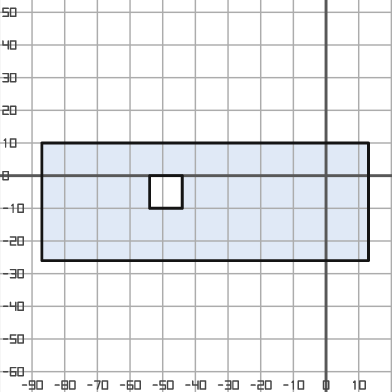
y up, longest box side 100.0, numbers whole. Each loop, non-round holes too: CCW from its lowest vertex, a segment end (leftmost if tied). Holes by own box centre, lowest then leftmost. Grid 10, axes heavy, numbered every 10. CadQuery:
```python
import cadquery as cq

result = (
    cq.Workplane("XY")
    .moveTo(-87.0, -26.0)
    .lineTo(13.0, -26.0)
    .lineTo(13.0, 10.0)
    .lineTo(-87.0, 10.0)
    .close()
    .moveTo(-54.0, -10.0)
    .lineTo(-44.0, -10.0)
    .lineTo(-44.0, 0.0)
    .lineTo(-54.0, 0.0)
    .close()
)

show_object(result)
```